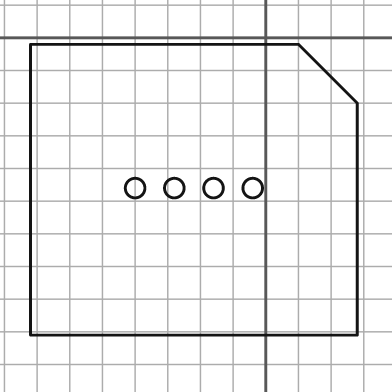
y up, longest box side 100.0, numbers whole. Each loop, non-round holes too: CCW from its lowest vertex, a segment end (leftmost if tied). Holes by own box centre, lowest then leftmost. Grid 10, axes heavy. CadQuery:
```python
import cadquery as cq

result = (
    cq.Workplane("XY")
    .moveTo(-72.0, -91.0)
    .lineTo(28.0, -91.0)
    .lineTo(28.0, -20.0)
    .lineTo(10.0, -2.0)
    .lineTo(-72.0, -2.0)
    .close()
    .moveTo(-40.0, -46.0)
    .circle(3.0)
    .moveTo(-28.0, -46.0)
    .circle(3.0)
    .moveTo(-16.0, -46.0)
    .circle(3.0)
    .moveTo(-4.0, -46.0)
    .circle(3.0)
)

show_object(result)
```